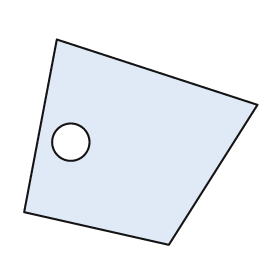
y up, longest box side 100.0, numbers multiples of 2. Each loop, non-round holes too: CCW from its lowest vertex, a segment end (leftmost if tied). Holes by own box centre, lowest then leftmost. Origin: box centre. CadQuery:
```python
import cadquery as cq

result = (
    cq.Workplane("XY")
    .moveTo(12.0, -44.0)
    .lineTo(50.0, 16.0)
    .lineTo(-36.0, 44.0)
    .lineTo(-50.0, -30.0)
    .close()
    .moveTo(-30.0, 0.0)
    .circle(8.0)
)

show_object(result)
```